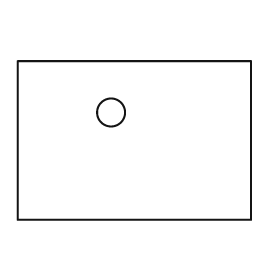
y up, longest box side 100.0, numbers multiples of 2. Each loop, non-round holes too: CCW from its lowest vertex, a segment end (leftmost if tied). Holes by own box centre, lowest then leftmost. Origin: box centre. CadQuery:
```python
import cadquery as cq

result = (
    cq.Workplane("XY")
    .moveTo(-50.0, -34.0)
    .lineTo(50.0, -34.0)
    .lineTo(50.0, 34.0)
    .lineTo(-50.0, 34.0)
    .close()
    .moveTo(-10.0, 12.0)
    .circle(6.0)
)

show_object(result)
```